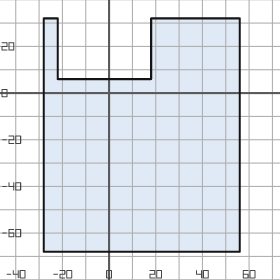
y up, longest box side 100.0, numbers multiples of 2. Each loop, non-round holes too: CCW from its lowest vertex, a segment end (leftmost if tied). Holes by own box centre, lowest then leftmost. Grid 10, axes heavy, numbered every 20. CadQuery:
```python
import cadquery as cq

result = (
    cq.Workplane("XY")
    .moveTo(-28.0, -68.0)
    .lineTo(56.0, -68.0)
    .lineTo(56.0, 32.0)
    .lineTo(18.0, 32.0)
    .lineTo(18.0, 6.0)
    .lineTo(-22.0, 6.0)
    .lineTo(-22.0, 32.0)
    .lineTo(-28.0, 32.0)
    .close()
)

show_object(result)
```